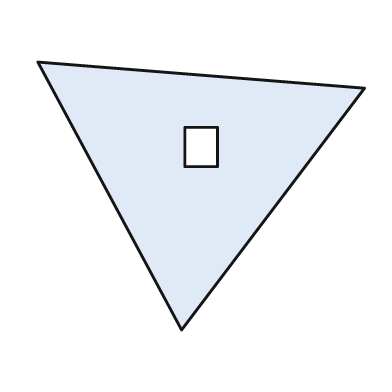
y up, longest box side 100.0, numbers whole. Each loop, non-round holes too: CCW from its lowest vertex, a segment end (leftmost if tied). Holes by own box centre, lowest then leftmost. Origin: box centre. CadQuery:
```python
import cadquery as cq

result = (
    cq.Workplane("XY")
    .moveTo(-6.0, -41.0)
    .lineTo(50.0, 33.0)
    .lineTo(-50.0, 41.0)
    .close()
    .moveTo(-5.0, 9.0)
    .lineTo(5.0, 9.0)
    .lineTo(5.0, 21.0)
    .lineTo(-5.0, 21.0)
    .close()
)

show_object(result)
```